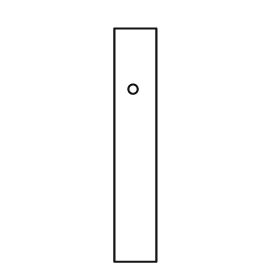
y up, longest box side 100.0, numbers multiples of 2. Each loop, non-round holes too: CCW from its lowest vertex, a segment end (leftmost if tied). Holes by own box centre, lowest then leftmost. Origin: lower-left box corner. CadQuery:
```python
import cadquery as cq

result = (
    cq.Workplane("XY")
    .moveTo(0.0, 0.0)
    .lineTo(18.0, 0.0)
    .lineTo(18.0, 100.0)
    .lineTo(0.0, 100.0)
    .close()
    .moveTo(8.0, 74.0)
    .circle(2.0)
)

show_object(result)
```